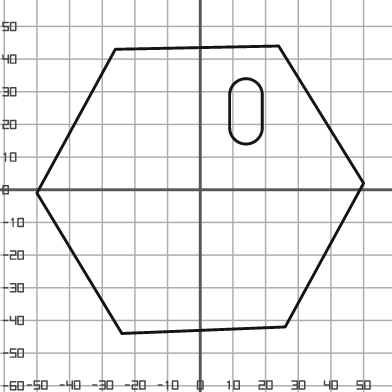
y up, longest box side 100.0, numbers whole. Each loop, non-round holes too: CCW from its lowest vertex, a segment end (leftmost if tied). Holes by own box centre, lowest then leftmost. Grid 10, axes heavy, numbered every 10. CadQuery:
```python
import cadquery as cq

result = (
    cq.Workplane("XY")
    .moveTo(-24.0, -44.0)
    .lineTo(26.0, -42.0)
    .lineTo(50.0, 2.0)
    .lineTo(24.0, 44.0)
    .lineTo(-26.0, 43.0)
    .lineTo(-50.0, -1.0)
    .close()
    .moveTo(9.0, 19.0)
    .threePointArc((14.0, 14.0), (19.0, 19.0))
    .lineTo(19.0, 29.0)
    .threePointArc((14.0, 34.0), (9.0, 29.0))
    .close()
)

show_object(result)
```